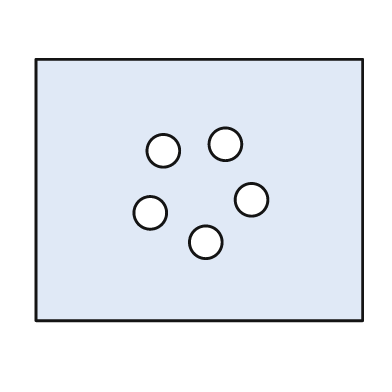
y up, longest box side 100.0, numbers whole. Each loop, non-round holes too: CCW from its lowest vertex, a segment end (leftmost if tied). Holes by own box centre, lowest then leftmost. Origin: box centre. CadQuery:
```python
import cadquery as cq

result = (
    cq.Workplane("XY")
    .moveTo(-50.0, -40.0)
    .lineTo(50.0, -40.0)
    .lineTo(50.0, 40.0)
    .lineTo(-50.0, 40.0)
    .close()
    .moveTo(2.0, -16.0)
    .circle(5.0)
    .moveTo(-15.0, -7.0)
    .circle(5.0)
    .moveTo(16.0, -3.0)
    .circle(5.0)
    .moveTo(-11.0, 12.0)
    .circle(5.0)
    .moveTo(8.0, 14.0)
    .circle(5.0)
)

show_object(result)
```